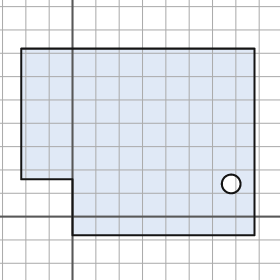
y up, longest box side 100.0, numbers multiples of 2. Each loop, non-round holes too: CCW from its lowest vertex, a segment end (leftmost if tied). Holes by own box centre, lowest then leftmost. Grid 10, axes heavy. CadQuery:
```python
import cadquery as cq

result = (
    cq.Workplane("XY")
    .moveTo(0.0, -8.0)
    .lineTo(78.0, -8.0)
    .lineTo(78.0, 72.0)
    .lineTo(-22.0, 72.0)
    .lineTo(-22.0, 16.0)
    .lineTo(0.0, 16.0)
    .close()
    .moveTo(68.0, 14.0)
    .circle(4.0)
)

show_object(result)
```